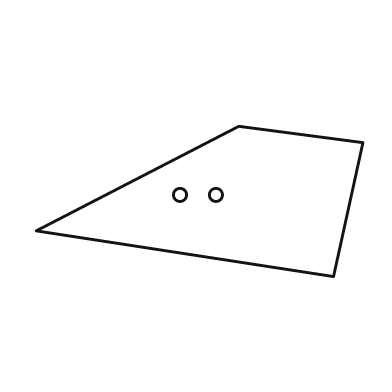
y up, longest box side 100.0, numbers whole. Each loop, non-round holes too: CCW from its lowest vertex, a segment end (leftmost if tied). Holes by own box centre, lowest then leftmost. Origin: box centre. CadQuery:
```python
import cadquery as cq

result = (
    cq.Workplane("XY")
    .moveTo(41.0, -23.0)
    .lineTo(50.0, 18.0)
    .lineTo(12.0, 23.0)
    .lineTo(-50.0, -9.0)
    .close()
    .moveTo(-6.0, 2.0)
    .circle(2.0)
    .moveTo(5.0, 2.0)
    .circle(2.0)
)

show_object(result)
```